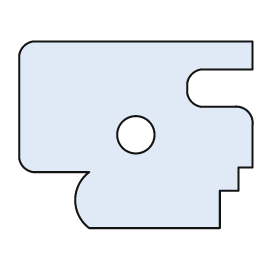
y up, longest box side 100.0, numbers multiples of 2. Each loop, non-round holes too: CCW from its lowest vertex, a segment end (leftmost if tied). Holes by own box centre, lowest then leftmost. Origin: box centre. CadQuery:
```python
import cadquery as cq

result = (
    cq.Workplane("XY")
    .moveTo(-20.0, -40.0)
    .lineTo(36.0, -40.0)
    .lineTo(36.0, -24.0)
    .lineTo(44.0, -24.0)
    .lineTo(44.0, -14.0)
    .lineTo(50.0, -14.0)
    .lineTo(50.0, 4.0)
    .threePointArc((48.0, 10.0), (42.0, 12.0))
    .lineTo(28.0, 12.0)
    .threePointArc((24.0, 14.0), (22.0, 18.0))
    .lineTo(22.0, 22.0)
    .threePointArc((24.0, 26.0), (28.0, 28.0))
    .lineTo(50.0, 28.0)
    .lineTo(50.0, 40.0)
    .lineTo(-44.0, 40.0)
    .threePointArc((-48.0, 38.0), (-50.0, 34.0))
    .lineTo(-50.0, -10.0)
    .threePointArc((-48.0, -14.0), (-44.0, -16.0))
    .lineTo(-20.0, -16.0)
    .threePointArc((-26.0, -28.0), (-20.0, -40.0))
    .close()
    .moveTo(0.0, 0.0)
    .circle(8.0)
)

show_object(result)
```